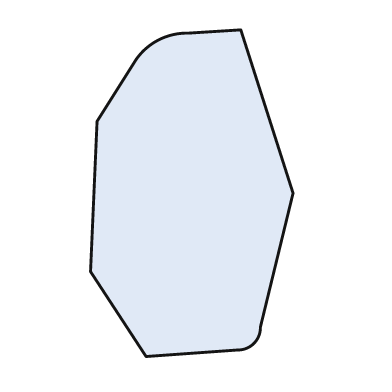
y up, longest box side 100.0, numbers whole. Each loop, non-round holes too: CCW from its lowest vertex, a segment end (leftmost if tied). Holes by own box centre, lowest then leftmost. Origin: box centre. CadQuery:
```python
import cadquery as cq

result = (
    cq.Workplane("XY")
    .moveTo(-14.0, -50.0)
    .lineTo(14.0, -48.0)
    .threePointArc((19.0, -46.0), (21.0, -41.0))
    .lineTo(31.0, 0.0)
    .lineTo(15.0, 50.0)
    .lineTo(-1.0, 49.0)
    .threePointArc((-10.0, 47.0), (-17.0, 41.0))
    .lineTo(-29.0, 22.0)
    .lineTo(-31.0, -24.0)
    .close()
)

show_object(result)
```